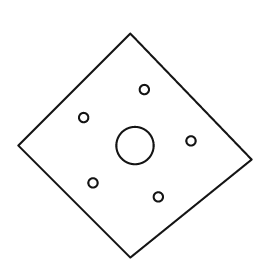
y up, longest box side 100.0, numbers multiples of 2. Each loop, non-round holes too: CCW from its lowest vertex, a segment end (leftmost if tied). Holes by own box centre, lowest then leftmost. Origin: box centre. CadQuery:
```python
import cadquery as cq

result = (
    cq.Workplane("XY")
    .moveTo(-2.0, -48.0)
    .lineTo(50.0, -6.0)
    .lineTo(-2.0, 48.0)
    .lineTo(-50.0, 0.0)
    .close()
    .moveTo(10.0, -22.0)
    .circle(2.0)
    .moveTo(-18.0, -16.0)
    .circle(2.0)
    .moveTo(0.0, 0.0)
    .circle(8.0)
    .moveTo(24.0, 2.0)
    .circle(2.0)
    .moveTo(-22.0, 12.0)
    .circle(2.0)
    .moveTo(4.0, 24.0)
    .circle(2.0)
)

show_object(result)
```